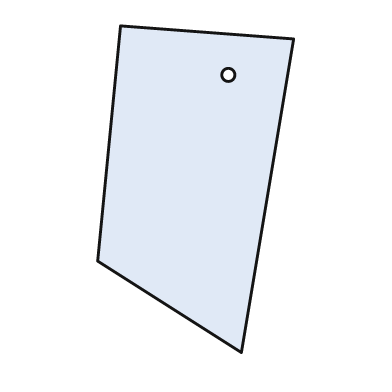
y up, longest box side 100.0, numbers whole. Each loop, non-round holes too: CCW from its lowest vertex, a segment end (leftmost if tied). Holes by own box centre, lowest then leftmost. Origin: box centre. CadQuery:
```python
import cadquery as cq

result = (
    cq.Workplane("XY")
    .moveTo(14.0, -50.0)
    .lineTo(30.0, 46.0)
    .lineTo(-23.0, 50.0)
    .lineTo(-30.0, -22.0)
    .close()
    .moveTo(10.0, 35.0)
    .circle(2.0)
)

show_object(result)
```